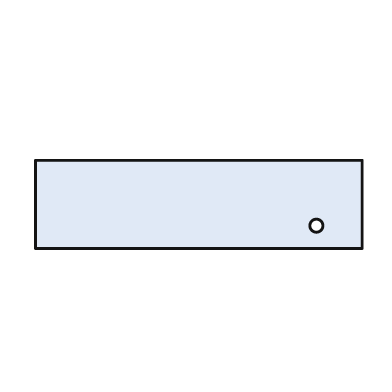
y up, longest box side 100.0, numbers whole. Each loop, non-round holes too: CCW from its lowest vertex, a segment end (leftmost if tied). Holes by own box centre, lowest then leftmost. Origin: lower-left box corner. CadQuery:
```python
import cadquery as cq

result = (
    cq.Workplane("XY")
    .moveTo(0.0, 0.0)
    .lineTo(100.0, 0.0)
    .lineTo(100.0, 27.0)
    .lineTo(0.0, 27.0)
    .close()
    .moveTo(86.0, 7.0)
    .circle(2.0)
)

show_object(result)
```